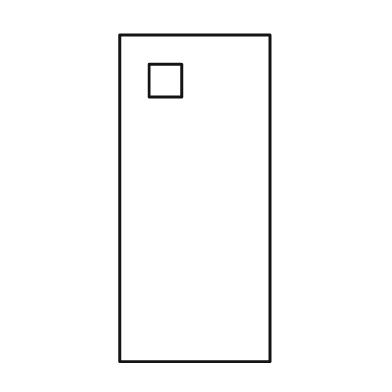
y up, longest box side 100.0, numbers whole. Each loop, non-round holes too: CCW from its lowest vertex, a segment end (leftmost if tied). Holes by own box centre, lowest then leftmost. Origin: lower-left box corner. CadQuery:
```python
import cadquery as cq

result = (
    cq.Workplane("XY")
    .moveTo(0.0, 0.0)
    .lineTo(46.0, 0.0)
    .lineTo(46.0, 100.0)
    .lineTo(0.0, 100.0)
    .close()
    .moveTo(9.0, 81.0)
    .lineTo(19.0, 81.0)
    .lineTo(19.0, 91.0)
    .lineTo(9.0, 91.0)
    .close()
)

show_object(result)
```